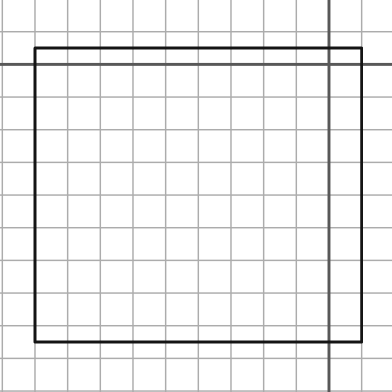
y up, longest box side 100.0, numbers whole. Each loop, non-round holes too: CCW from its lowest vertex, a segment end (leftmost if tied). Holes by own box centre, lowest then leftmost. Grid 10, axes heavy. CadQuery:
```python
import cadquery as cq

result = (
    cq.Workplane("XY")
    .moveTo(-90.0, -85.0)
    .lineTo(10.0, -85.0)
    .lineTo(10.0, 5.0)
    .lineTo(-90.0, 5.0)
    .close()
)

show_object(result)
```